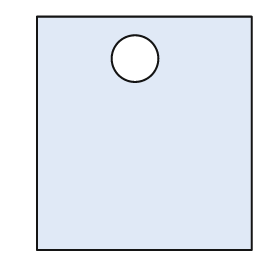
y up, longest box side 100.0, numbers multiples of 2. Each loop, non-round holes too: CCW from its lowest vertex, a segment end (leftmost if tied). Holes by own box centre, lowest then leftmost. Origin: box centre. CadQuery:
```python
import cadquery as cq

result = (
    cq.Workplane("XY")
    .moveTo(-46.0, -50.0)
    .lineTo(46.0, -50.0)
    .lineTo(46.0, 50.0)
    .lineTo(-46.0, 50.0)
    .close()
    .moveTo(-4.0, 32.0)
    .circle(10.0)
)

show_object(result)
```